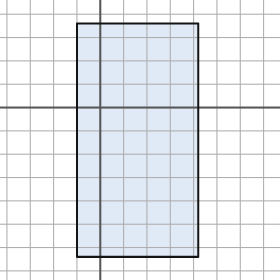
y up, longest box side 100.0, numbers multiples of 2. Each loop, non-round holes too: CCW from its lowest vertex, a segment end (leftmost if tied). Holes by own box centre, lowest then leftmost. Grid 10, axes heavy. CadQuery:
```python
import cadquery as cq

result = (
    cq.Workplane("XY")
    .moveTo(-10.0, -64.0)
    .lineTo(42.0, -64.0)
    .lineTo(42.0, 36.0)
    .lineTo(-10.0, 36.0)
    .close()
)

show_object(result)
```